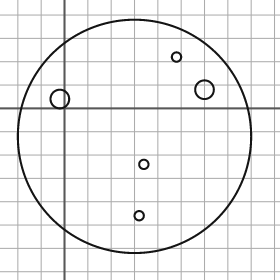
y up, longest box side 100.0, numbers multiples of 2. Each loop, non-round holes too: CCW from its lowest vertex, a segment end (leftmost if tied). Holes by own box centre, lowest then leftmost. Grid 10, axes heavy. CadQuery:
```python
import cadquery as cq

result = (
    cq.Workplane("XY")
    .moveTo(30.0, -12.0)
    .circle(50.0)
    .moveTo(32.0, -46.0)
    .circle(2.0)
    .moveTo(34.0, -24.0)
    .circle(2.0)
    .moveTo(-2.0, 4.0)
    .circle(4.0)
    .moveTo(60.0, 8.0)
    .circle(4.0)
    .moveTo(48.0, 22.0)
    .circle(2.0)
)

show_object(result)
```